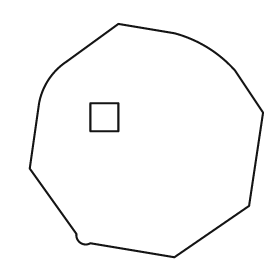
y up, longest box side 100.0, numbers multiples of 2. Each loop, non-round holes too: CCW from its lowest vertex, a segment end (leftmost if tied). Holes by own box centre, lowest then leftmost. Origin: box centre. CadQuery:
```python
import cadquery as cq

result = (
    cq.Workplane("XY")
    .moveTo(12.0, -50.0)
    .lineTo(44.0, -28.0)
    .lineTo(50.0, 12.0)
    .lineTo(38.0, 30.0)
    .threePointArc((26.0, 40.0), (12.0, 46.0))
    .lineTo(-12.0, 50.0)
    .lineTo(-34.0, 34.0)
    .threePointArc((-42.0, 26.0), (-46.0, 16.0))
    .lineTo(-50.0, -12.0)
    .lineTo(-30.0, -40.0)
    .threePointArc((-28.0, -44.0), (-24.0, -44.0))
    .close()
    .moveTo(-24.0, 4.0)
    .lineTo(-12.0, 4.0)
    .lineTo(-12.0, 16.0)
    .lineTo(-24.0, 16.0)
    .close()
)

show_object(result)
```